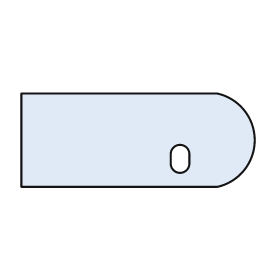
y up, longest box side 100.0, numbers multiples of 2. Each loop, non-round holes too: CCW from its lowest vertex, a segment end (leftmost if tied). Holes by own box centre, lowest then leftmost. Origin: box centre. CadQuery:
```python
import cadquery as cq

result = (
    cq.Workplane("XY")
    .moveTo(-50.0, -20.0)
    .lineTo(34.0, -20.0)
    .threePointArc((50.0, 0.0), (34.0, 20.0))
    .lineTo(-50.0, 20.0)
    .close()
    .moveTo(14.0, -10.0)
    .threePointArc((18.0, -14.0), (22.0, -10.0))
    .lineTo(22.0, -6.0)
    .threePointArc((18.0, -2.0), (14.0, -6.0))
    .close()
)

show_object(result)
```